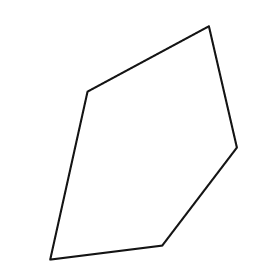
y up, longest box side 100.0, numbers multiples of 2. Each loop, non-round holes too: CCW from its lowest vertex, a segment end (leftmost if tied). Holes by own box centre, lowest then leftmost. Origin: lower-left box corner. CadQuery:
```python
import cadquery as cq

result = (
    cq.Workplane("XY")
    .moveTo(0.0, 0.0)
    .lineTo(48.0, 6.0)
    .lineTo(80.0, 48.0)
    .lineTo(68.0, 100.0)
    .lineTo(16.0, 72.0)
    .close()
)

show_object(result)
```